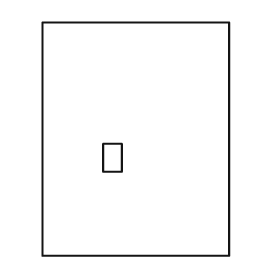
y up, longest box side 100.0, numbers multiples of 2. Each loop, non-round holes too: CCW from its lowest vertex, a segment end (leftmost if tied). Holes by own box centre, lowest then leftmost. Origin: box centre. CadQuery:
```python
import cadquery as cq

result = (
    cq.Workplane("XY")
    .moveTo(-40.0, -50.0)
    .lineTo(40.0, -50.0)
    .lineTo(40.0, 50.0)
    .lineTo(-40.0, 50.0)
    .close()
    .moveTo(-14.0, -14.0)
    .lineTo(-6.0, -14.0)
    .lineTo(-6.0, -2.0)
    .lineTo(-14.0, -2.0)
    .close()
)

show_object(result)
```